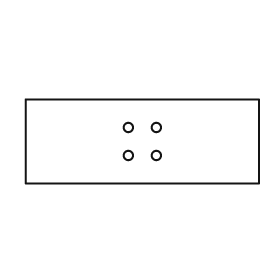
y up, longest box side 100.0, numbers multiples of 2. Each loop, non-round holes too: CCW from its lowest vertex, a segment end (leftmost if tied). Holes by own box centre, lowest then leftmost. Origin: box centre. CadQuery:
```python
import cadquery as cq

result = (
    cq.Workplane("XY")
    .moveTo(-50.0, -18.0)
    .lineTo(50.0, -18.0)
    .lineTo(50.0, 18.0)
    .lineTo(-50.0, 18.0)
    .close()
    .moveTo(-6.0, -6.0)
    .circle(2.0)
    .moveTo(6.0, -6.0)
    .circle(2.0)
    .moveTo(-6.0, 6.0)
    .circle(2.0)
    .moveTo(6.0, 6.0)
    .circle(2.0)
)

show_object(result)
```